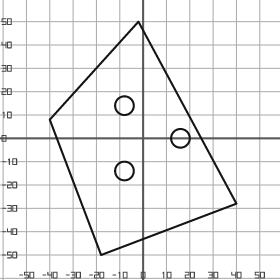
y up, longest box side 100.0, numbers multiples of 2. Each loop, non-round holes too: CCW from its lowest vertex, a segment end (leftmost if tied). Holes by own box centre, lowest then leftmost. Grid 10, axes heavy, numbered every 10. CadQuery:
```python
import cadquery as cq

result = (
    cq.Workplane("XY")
    .moveTo(-18.0, -50.0)
    .lineTo(40.0, -28.0)
    .lineTo(-2.0, 50.0)
    .lineTo(-40.0, 8.0)
    .close()
    .moveTo(-8.0, -14.0)
    .circle(4.0)
    .moveTo(16.0, 0.0)
    .circle(4.0)
    .moveTo(-8.0, 14.0)
    .circle(4.0)
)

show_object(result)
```